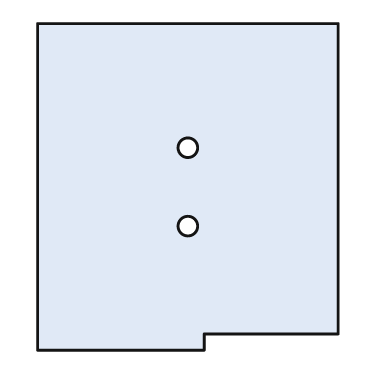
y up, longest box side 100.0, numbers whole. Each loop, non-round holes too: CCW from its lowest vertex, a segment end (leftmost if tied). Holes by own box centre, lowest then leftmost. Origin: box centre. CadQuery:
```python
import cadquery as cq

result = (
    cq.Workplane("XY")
    .moveTo(-46.0, -50.0)
    .lineTo(5.0, -50.0)
    .lineTo(5.0, -45.0)
    .lineTo(46.0, -45.0)
    .lineTo(46.0, 50.0)
    .lineTo(-46.0, 50.0)
    .close()
    .moveTo(0.0, -12.0)
    .circle(3.0)
    .moveTo(0.0, 12.0)
    .circle(3.0)
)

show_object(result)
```